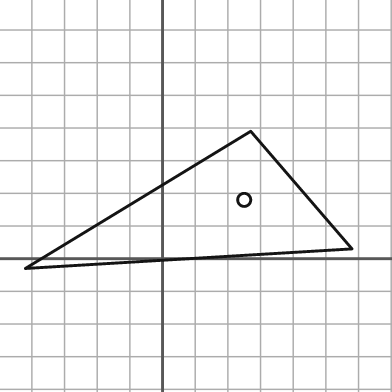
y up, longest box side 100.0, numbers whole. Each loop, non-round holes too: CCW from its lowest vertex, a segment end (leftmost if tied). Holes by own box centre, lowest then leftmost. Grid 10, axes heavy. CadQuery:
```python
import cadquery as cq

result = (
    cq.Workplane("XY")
    .moveTo(-42.0, -3.0)
    .lineTo(58.0, 3.0)
    .lineTo(27.0, 39.0)
    .close()
    .moveTo(25.0, 18.0)
    .circle(2.0)
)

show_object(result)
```